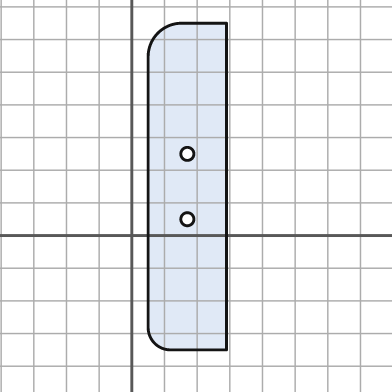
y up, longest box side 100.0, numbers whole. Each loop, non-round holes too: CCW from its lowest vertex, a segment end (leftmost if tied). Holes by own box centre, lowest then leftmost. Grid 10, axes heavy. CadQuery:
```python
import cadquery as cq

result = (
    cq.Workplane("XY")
    .moveTo(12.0, -35.0)
    .lineTo(29.0, -35.0)
    .lineTo(29.0, 65.0)
    .lineTo(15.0, 65.0)
    .threePointArc((8.0, 62.0), (5.0, 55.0))
    .lineTo(5.0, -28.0)
    .threePointArc((7.0, -33.0), (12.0, -35.0))
    .close()
    .moveTo(17.0, 5.0)
    .circle(2.0)
    .moveTo(17.0, 25.0)
    .circle(2.0)
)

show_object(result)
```